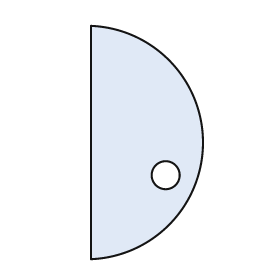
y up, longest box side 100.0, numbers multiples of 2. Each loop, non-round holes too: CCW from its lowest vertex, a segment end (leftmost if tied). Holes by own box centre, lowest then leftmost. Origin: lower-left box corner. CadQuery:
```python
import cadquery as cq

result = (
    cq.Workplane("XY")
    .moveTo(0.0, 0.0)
    .threePointArc((48.0, 50.0), (0.0, 100.0))
    .close()
    .moveTo(32.0, 36.0)
    .circle(6.0)
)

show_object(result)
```